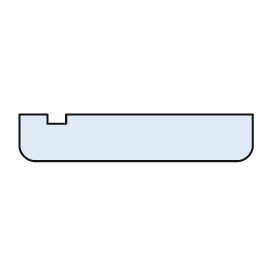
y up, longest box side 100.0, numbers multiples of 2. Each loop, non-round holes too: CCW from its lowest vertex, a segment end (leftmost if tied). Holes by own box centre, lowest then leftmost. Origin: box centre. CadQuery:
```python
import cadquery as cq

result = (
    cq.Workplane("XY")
    .moveTo(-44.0, -10.0)
    .lineTo(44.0, -10.0)
    .threePointArc((48.0, -8.0), (50.0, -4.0))
    .lineTo(50.0, 10.0)
    .lineTo(-30.0, 10.0)
    .lineTo(-30.0, 6.0)
    .lineTo(-38.0, 6.0)
    .lineTo(-38.0, 10.0)
    .lineTo(-50.0, 10.0)
    .lineTo(-50.0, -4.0)
    .threePointArc((-48.0, -8.0), (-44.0, -10.0))
    .close()
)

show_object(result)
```